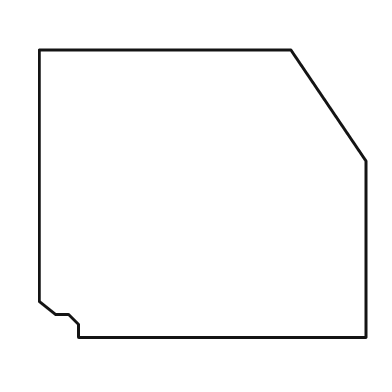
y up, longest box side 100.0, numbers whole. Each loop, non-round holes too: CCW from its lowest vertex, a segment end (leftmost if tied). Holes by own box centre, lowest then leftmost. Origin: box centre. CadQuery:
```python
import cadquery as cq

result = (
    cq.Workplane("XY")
    .moveTo(-38.0, -44.0)
    .lineTo(50.0, -44.0)
    .lineTo(50.0, 10.0)
    .lineTo(27.0, 44.0)
    .lineTo(-50.0, 44.0)
    .lineTo(-50.0, -33.0)
    .lineTo(-45.0, -37.0)
    .lineTo(-41.0, -37.0)
    .lineTo(-38.0, -40.0)
    .close()
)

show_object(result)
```